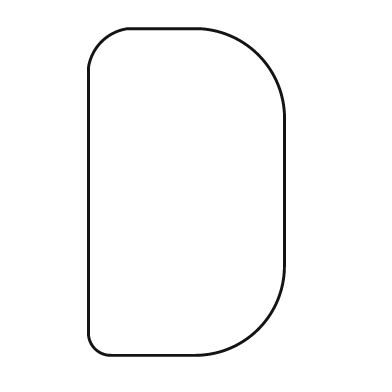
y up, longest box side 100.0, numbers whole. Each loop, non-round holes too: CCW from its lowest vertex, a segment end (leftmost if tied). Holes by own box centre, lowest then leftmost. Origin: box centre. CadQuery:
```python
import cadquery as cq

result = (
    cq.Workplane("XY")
    .moveTo(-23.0, -50.0)
    .lineTo(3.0, -50.0)
    .threePointArc((22.0, -42.0), (30.0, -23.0))
    .lineTo(30.0, 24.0)
    .threePointArc((22.0, 42.0), (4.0, 50.0))
    .lineTo(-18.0, 50.0)
    .threePointArc((-26.0, 46.0), (-30.0, 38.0))
    .lineTo(-30.0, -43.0)
    .threePointArc((-28.0, -48.0), (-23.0, -50.0))
    .close()
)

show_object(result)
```